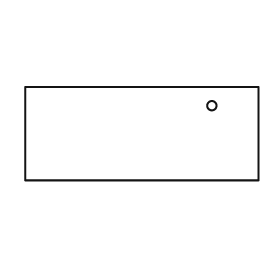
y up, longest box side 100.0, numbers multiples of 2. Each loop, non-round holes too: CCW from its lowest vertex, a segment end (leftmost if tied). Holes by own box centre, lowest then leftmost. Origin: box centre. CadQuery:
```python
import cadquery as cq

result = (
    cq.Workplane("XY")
    .moveTo(-50.0, -20.0)
    .lineTo(50.0, -20.0)
    .lineTo(50.0, 20.0)
    .lineTo(-50.0, 20.0)
    .close()
    .moveTo(30.0, 12.0)
    .circle(2.0)
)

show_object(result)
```